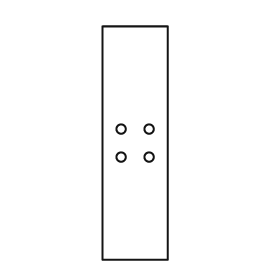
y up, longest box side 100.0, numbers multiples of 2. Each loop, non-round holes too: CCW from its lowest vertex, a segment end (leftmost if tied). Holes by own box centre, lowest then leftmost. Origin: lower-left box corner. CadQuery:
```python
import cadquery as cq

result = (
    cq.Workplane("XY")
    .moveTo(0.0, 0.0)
    .lineTo(28.0, 0.0)
    .lineTo(28.0, 100.0)
    .lineTo(0.0, 100.0)
    .close()
    .moveTo(8.0, 44.0)
    .circle(2.0)
    .moveTo(20.0, 44.0)
    .circle(2.0)
    .moveTo(8.0, 56.0)
    .circle(2.0)
    .moveTo(20.0, 56.0)
    .circle(2.0)
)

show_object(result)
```